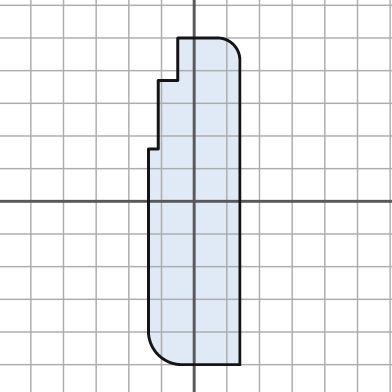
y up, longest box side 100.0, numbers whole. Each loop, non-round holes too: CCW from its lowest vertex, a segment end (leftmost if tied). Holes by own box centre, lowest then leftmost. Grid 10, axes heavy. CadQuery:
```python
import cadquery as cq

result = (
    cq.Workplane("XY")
    .moveTo(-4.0, -50.0)
    .lineTo(14.0, -50.0)
    .lineTo(14.0, 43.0)
    .threePointArc((12.0, 48.0), (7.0, 50.0))
    .lineTo(-5.0, 50.0)
    .lineTo(-5.0, 37.0)
    .lineTo(-11.0, 37.0)
    .lineTo(-11.0, 16.0)
    .lineTo(-14.0, 16.0)
    .lineTo(-14.0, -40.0)
    .threePointArc((-11.0, -47.0), (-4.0, -50.0))
    .close()
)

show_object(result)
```